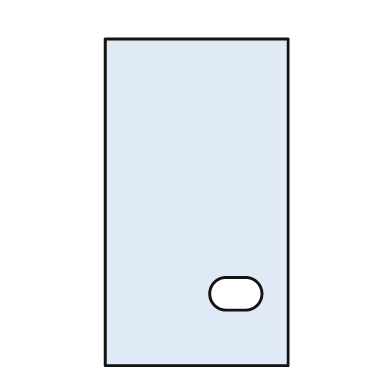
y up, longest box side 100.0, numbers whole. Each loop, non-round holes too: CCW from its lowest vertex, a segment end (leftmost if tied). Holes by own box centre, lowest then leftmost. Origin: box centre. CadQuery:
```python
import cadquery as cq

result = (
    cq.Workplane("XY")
    .moveTo(-28.0, -50.0)
    .lineTo(28.0, -50.0)
    .lineTo(28.0, 50.0)
    .lineTo(-28.0, 50.0)
    .close()
    .moveTo(9.0, -33.0)
    .lineTo(15.0, -33.0)
    .threePointArc((20.0, -28.0), (15.0, -23.0))
    .lineTo(9.0, -23.0)
    .threePointArc((4.0, -28.0), (9.0, -33.0))
    .close()
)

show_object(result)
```